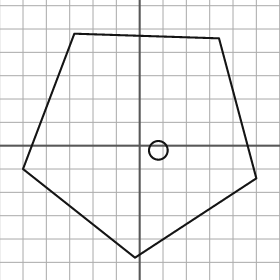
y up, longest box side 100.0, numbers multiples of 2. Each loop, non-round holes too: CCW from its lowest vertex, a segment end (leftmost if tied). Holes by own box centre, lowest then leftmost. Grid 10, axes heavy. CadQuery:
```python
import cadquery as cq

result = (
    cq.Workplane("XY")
    .moveTo(-2.0, -48.0)
    .lineTo(50.0, -14.0)
    .lineTo(34.0, 46.0)
    .lineTo(-28.0, 48.0)
    .lineTo(-50.0, -10.0)
    .close()
    .moveTo(8.0, -2.0)
    .circle(4.0)
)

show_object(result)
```